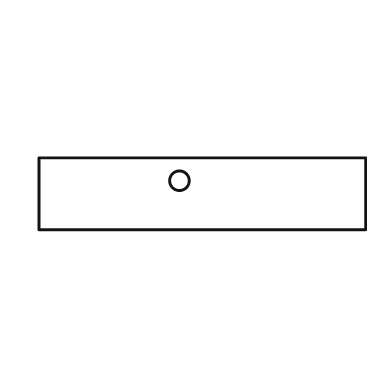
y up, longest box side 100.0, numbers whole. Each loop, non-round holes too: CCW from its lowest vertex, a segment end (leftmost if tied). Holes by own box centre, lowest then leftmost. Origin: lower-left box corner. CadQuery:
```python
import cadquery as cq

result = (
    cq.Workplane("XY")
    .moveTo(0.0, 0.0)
    .lineTo(100.0, 0.0)
    .lineTo(100.0, 22.0)
    .lineTo(0.0, 22.0)
    .close()
    .moveTo(43.0, 15.0)
    .circle(3.0)
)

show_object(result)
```